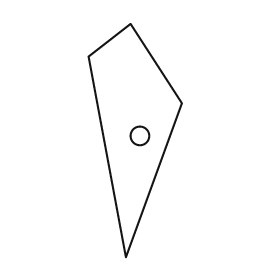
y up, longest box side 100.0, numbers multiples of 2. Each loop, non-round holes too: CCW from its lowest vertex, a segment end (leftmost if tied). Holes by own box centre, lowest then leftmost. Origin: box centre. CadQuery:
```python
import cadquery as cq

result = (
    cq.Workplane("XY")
    .moveTo(-4.0, -50.0)
    .lineTo(20.0, 16.0)
    .lineTo(-2.0, 50.0)
    .lineTo(-20.0, 36.0)
    .close()
    .moveTo(2.0, 2.0)
    .circle(4.0)
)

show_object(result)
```